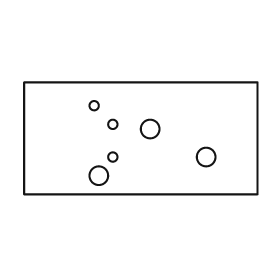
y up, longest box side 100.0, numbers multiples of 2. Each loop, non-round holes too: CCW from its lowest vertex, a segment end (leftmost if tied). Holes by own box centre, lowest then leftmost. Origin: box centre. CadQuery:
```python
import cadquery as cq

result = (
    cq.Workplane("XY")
    .moveTo(-50.0, -24.0)
    .lineTo(50.0, -24.0)
    .lineTo(50.0, 24.0)
    .lineTo(-50.0, 24.0)
    .close()
    .moveTo(-18.0, -16.0)
    .circle(4.0)
    .moveTo(-12.0, -8.0)
    .circle(2.0)
    .moveTo(28.0, -8.0)
    .circle(4.0)
    .moveTo(4.0, 4.0)
    .circle(4.0)
    .moveTo(-12.0, 6.0)
    .circle(2.0)
    .moveTo(-20.0, 14.0)
    .circle(2.0)
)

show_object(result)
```